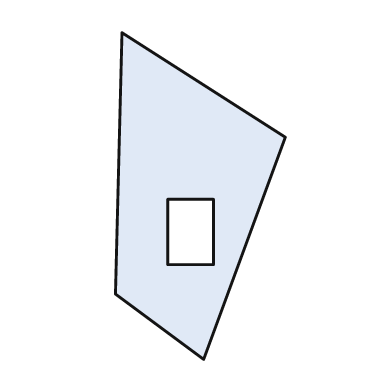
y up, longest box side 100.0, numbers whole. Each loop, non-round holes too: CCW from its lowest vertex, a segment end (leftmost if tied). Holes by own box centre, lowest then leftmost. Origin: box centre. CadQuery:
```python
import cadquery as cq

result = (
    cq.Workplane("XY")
    .moveTo(1.0, -50.0)
    .lineTo(26.0, 18.0)
    .lineTo(-24.0, 50.0)
    .lineTo(-26.0, -30.0)
    .close()
    .moveTo(-10.0, -21.0)
    .lineTo(4.0, -21.0)
    .lineTo(4.0, -1.0)
    .lineTo(-10.0, -1.0)
    .close()
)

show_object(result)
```